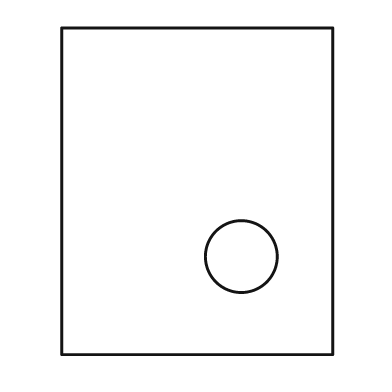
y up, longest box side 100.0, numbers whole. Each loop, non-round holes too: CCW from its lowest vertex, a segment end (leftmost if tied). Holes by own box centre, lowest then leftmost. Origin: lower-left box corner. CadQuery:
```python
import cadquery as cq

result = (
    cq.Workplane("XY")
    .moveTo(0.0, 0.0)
    .lineTo(83.0, 0.0)
    .lineTo(83.0, 100.0)
    .lineTo(0.0, 100.0)
    .close()
    .moveTo(55.0, 30.0)
    .circle(11.0)
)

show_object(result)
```